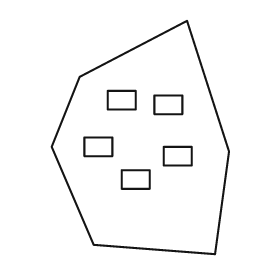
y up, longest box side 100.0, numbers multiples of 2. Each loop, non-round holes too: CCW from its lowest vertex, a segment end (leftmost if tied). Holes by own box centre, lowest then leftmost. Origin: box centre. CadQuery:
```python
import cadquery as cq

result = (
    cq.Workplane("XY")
    .moveTo(32.0, -50.0)
    .lineTo(38.0, -6.0)
    .lineTo(20.0, 50.0)
    .lineTo(-26.0, 26.0)
    .lineTo(-38.0, -4.0)
    .lineTo(-20.0, -46.0)
    .close()
    .moveTo(-8.0, -22.0)
    .lineTo(4.0, -22.0)
    .lineTo(4.0, -14.0)
    .lineTo(-8.0, -14.0)
    .close()
    .moveTo(10.0, -12.0)
    .lineTo(22.0, -12.0)
    .lineTo(22.0, -4.0)
    .lineTo(10.0, -4.0)
    .close()
    .moveTo(-24.0, -8.0)
    .lineTo(-12.0, -8.0)
    .lineTo(-12.0, 0.0)
    .lineTo(-24.0, 0.0)
    .close()
    .moveTo(6.0, 10.0)
    .lineTo(18.0, 10.0)
    .lineTo(18.0, 18.0)
    .lineTo(6.0, 18.0)
    .close()
    .moveTo(-14.0, 12.0)
    .lineTo(-2.0, 12.0)
    .lineTo(-2.0, 20.0)
    .lineTo(-14.0, 20.0)
    .close()
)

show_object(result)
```